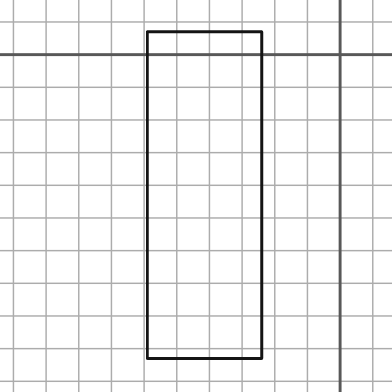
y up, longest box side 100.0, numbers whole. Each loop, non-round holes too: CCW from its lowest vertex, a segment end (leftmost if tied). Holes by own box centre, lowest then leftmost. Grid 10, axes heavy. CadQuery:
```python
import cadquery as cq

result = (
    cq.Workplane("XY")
    .moveTo(-59.0, -93.0)
    .lineTo(-24.0, -93.0)
    .lineTo(-24.0, 7.0)
    .lineTo(-59.0, 7.0)
    .close()
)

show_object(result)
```